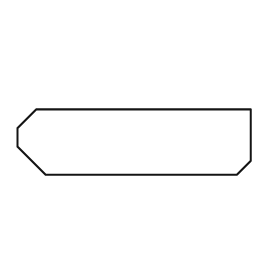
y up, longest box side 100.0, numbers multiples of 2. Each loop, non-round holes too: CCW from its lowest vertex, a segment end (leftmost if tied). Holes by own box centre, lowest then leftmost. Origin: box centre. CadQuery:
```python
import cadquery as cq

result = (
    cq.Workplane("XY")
    .moveTo(-38.0, -14.0)
    .lineTo(44.0, -14.0)
    .lineTo(50.0, -8.0)
    .lineTo(50.0, 14.0)
    .lineTo(-42.0, 14.0)
    .lineTo(-50.0, 6.0)
    .lineTo(-50.0, -2.0)
    .close()
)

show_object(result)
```